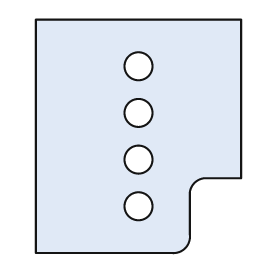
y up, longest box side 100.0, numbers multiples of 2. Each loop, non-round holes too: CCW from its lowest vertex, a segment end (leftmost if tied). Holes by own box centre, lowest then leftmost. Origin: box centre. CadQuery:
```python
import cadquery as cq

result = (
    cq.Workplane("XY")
    .moveTo(-44.0, -50.0)
    .lineTo(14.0, -50.0)
    .threePointArc((20.0, -48.0), (22.0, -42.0))
    .lineTo(22.0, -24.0)
    .threePointArc((24.0, -20.0), (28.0, -18.0))
    .lineTo(44.0, -18.0)
    .lineTo(44.0, 50.0)
    .lineTo(-44.0, 50.0)
    .close()
    .moveTo(0.0, -30.0)
    .circle(6.0)
    .moveTo(0.0, -10.0)
    .circle(6.0)
    .moveTo(0.0, 10.0)
    .circle(6.0)
    .moveTo(0.0, 30.0)
    .circle(6.0)
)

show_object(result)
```